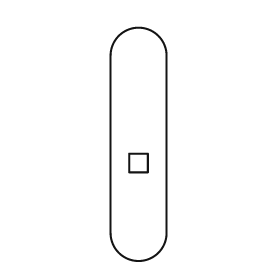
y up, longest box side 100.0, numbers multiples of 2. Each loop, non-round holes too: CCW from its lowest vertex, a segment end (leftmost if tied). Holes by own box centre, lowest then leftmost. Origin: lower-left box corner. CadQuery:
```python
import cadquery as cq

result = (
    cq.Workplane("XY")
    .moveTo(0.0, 12.0)
    .threePointArc((12.0, 0.0), (24.0, 12.0))
    .lineTo(24.0, 88.0)
    .threePointArc((12.0, 100.0), (0.0, 88.0))
    .close()
    .moveTo(8.0, 38.0)
    .lineTo(16.0, 38.0)
    .lineTo(16.0, 46.0)
    .lineTo(8.0, 46.0)
    .close()
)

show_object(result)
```